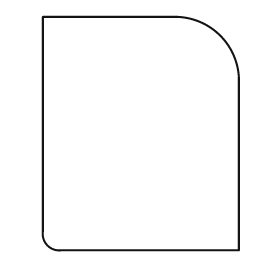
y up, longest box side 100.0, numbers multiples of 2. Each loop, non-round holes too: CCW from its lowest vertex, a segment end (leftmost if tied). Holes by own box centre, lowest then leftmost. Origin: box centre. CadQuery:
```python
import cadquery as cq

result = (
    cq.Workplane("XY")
    .moveTo(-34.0, -50.0)
    .lineTo(42.0, -50.0)
    .lineTo(42.0, 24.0)
    .threePointArc((34.0, 42.0), (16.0, 50.0))
    .lineTo(-42.0, 50.0)
    .lineTo(-42.0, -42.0)
    .threePointArc((-40.0, -48.0), (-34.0, -50.0))
    .close()
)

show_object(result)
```